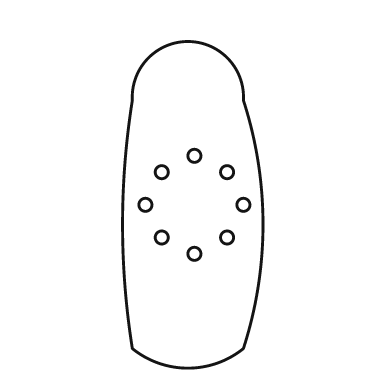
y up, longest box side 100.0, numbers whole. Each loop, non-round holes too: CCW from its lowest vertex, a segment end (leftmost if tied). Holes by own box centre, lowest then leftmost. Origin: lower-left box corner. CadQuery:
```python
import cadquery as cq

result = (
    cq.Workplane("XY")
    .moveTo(3.0, 6.0)
    .threePointArc((20.0, 0.0), (37.0, 6.0))
    .threePointArc((43.0, 44.0), (37.0, 82.0))
    .threePointArc((20.0, 100.0), (3.0, 82.0))
    .threePointArc((0.0, 44.0), (3.0, 6.0))
    .close()
    .moveTo(22.0, 35.0)
    .circle(2.0)
    .moveTo(12.0, 40.0)
    .circle(2.0)
    .moveTo(32.0, 40.0)
    .circle(2.0)
    .moveTo(7.0, 50.0)
    .circle(2.0)
    .moveTo(37.0, 50.0)
    .circle(2.0)
    .moveTo(12.0, 60.0)
    .circle(2.0)
    .moveTo(32.0, 60.0)
    .circle(2.0)
    .moveTo(22.0, 65.0)
    .circle(2.0)
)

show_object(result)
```